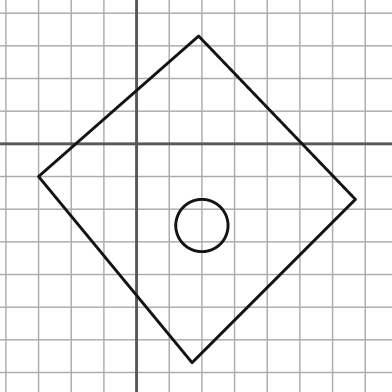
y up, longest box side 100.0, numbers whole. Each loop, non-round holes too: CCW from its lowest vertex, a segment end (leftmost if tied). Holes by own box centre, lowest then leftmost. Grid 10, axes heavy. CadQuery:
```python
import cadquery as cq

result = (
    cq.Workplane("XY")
    .moveTo(17.0, -67.0)
    .lineTo(67.0, -17.0)
    .lineTo(19.0, 33.0)
    .lineTo(-30.0, -10.0)
    .close()
    .moveTo(20.0, -25.0)
    .circle(8.0)
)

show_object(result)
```